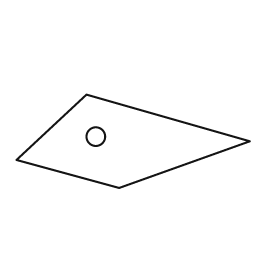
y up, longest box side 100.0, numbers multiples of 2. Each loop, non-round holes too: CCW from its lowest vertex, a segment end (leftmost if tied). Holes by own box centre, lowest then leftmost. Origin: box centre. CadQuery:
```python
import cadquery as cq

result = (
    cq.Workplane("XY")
    .moveTo(-6.0, -20.0)
    .lineTo(50.0, 0.0)
    .lineTo(-20.0, 20.0)
    .lineTo(-50.0, -8.0)
    .close()
    .moveTo(-16.0, 2.0)
    .circle(4.0)
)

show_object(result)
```